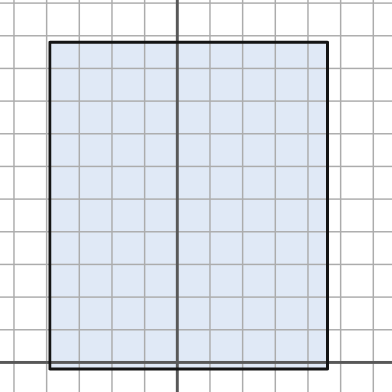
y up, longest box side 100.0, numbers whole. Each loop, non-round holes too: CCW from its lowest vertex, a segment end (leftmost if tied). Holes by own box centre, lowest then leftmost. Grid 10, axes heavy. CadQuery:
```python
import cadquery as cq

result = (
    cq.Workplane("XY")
    .moveTo(-39.0, -2.0)
    .lineTo(46.0, -2.0)
    .lineTo(46.0, 98.0)
    .lineTo(-39.0, 98.0)
    .close()
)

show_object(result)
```